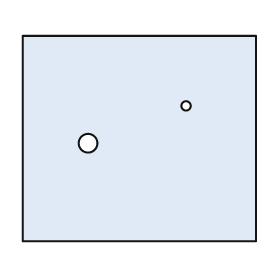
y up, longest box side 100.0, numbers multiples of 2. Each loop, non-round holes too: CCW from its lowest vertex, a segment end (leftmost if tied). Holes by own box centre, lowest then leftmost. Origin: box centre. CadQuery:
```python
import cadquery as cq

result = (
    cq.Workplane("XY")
    .moveTo(-50.0, -44.0)
    .lineTo(50.0, -44.0)
    .lineTo(50.0, 44.0)
    .lineTo(-50.0, 44.0)
    .close()
    .moveTo(-22.0, -2.0)
    .circle(4.0)
    .moveTo(20.0, 14.0)
    .circle(2.0)
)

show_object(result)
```